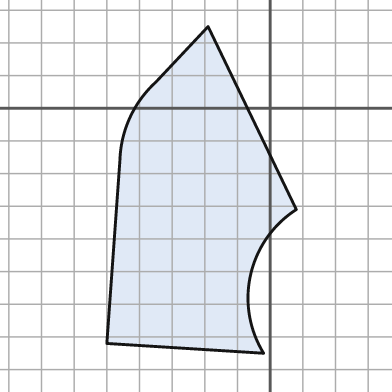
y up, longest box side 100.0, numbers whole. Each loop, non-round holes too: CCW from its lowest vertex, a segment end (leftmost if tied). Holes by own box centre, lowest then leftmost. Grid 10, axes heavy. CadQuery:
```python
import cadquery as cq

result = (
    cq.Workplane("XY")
    .moveTo(-2.0, -75.0)
    .threePointArc((-6.0, -51.0), (8.0, -31.0))
    .lineTo(-19.0, 25.0)
    .lineTo(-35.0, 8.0)
    .threePointArc((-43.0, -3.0), (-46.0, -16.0))
    .lineTo(-50.0, -72.0)
    .close()
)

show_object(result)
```